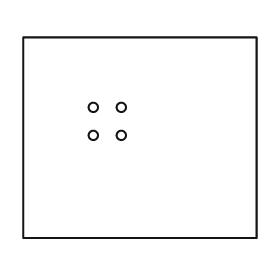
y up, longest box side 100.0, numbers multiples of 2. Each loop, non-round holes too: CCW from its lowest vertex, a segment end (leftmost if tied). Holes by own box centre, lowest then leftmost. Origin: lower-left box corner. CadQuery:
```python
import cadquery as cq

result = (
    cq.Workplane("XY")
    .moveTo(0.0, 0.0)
    .lineTo(100.0, 0.0)
    .lineTo(100.0, 86.0)
    .lineTo(0.0, 86.0)
    .close()
    .moveTo(30.0, 44.0)
    .circle(2.0)
    .moveTo(42.0, 44.0)
    .circle(2.0)
    .moveTo(30.0, 56.0)
    .circle(2.0)
    .moveTo(42.0, 56.0)
    .circle(2.0)
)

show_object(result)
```